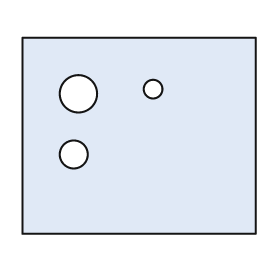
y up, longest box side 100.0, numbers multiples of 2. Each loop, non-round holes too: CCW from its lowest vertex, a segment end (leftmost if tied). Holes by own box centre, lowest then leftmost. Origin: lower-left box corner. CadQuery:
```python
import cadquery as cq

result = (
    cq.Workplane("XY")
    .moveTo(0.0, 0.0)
    .lineTo(100.0, 0.0)
    .lineTo(100.0, 84.0)
    .lineTo(0.0, 84.0)
    .close()
    .moveTo(22.0, 34.0)
    .circle(6.0)
    .moveTo(24.0, 60.0)
    .circle(8.0)
    .moveTo(56.0, 62.0)
    .circle(4.0)
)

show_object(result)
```